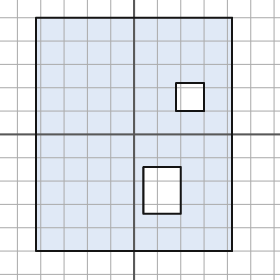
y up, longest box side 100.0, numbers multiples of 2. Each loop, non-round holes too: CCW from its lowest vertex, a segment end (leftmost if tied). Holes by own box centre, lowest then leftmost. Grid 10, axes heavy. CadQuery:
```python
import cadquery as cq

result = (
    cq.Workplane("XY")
    .moveTo(-42.0, -50.0)
    .lineTo(42.0, -50.0)
    .lineTo(42.0, 50.0)
    .lineTo(-42.0, 50.0)
    .close()
    .moveTo(4.0, -34.0)
    .lineTo(20.0, -34.0)
    .lineTo(20.0, -14.0)
    .lineTo(4.0, -14.0)
    .close()
    .moveTo(18.0, 10.0)
    .lineTo(30.0, 10.0)
    .lineTo(30.0, 22.0)
    .lineTo(18.0, 22.0)
    .close()
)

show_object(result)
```